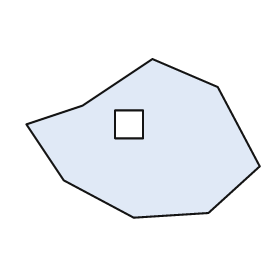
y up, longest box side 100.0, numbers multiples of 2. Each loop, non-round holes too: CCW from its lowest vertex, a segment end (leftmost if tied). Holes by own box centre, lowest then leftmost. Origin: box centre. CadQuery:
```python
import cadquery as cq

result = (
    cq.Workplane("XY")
    .moveTo(-4.0, -34.0)
    .lineTo(28.0, -32.0)
    .lineTo(50.0, -12.0)
    .lineTo(32.0, 22.0)
    .lineTo(4.0, 34.0)
    .lineTo(-26.0, 14.0)
    .lineTo(-50.0, 6.0)
    .lineTo(-34.0, -18.0)
    .close()
    .moveTo(-12.0, 0.0)
    .lineTo(0.0, 0.0)
    .lineTo(0.0, 12.0)
    .lineTo(-12.0, 12.0)
    .close()
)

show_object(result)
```